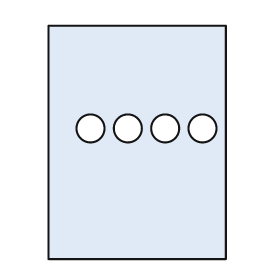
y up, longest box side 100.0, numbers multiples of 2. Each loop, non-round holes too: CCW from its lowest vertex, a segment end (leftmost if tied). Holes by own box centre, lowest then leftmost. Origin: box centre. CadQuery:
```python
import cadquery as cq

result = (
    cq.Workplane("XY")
    .moveTo(-38.0, -50.0)
    .lineTo(38.0, -50.0)
    .lineTo(38.0, 50.0)
    .lineTo(-38.0, 50.0)
    .close()
    .moveTo(-20.0, 6.0)
    .circle(6.0)
    .moveTo(-4.0, 6.0)
    .circle(6.0)
    .moveTo(12.0, 6.0)
    .circle(6.0)
    .moveTo(28.0, 6.0)
    .circle(6.0)
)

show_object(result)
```